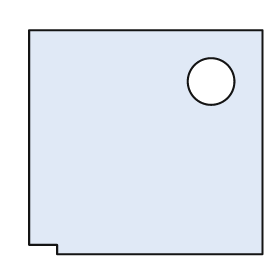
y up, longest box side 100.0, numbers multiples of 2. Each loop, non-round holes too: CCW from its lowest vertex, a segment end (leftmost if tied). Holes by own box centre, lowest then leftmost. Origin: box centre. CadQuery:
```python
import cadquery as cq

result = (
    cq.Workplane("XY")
    .moveTo(-38.0, -48.0)
    .lineTo(50.0, -48.0)
    .lineTo(50.0, 48.0)
    .lineTo(-50.0, 48.0)
    .lineTo(-50.0, -44.0)
    .lineTo(-38.0, -44.0)
    .close()
    .moveTo(28.0, 26.0)
    .circle(10.0)
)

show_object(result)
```